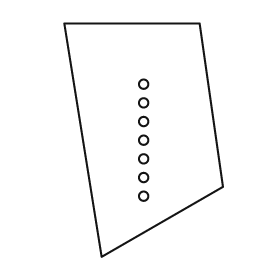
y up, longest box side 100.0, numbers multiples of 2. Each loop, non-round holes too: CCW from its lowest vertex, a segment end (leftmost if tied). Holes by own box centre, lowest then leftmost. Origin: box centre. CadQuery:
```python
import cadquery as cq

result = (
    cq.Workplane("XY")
    .moveTo(-18.0, -50.0)
    .lineTo(34.0, -20.0)
    .lineTo(24.0, 50.0)
    .lineTo(-34.0, 50.0)
    .close()
    .moveTo(0.0, -24.0)
    .circle(2.0)
    .moveTo(0.0, -16.0)
    .circle(2.0)
    .moveTo(0.0, -8.0)
    .circle(2.0)
    .moveTo(0.0, 0.0)
    .circle(2.0)
    .moveTo(0.0, 8.0)
    .circle(2.0)
    .moveTo(0.0, 16.0)
    .circle(2.0)
    .moveTo(0.0, 24.0)
    .circle(2.0)
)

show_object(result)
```